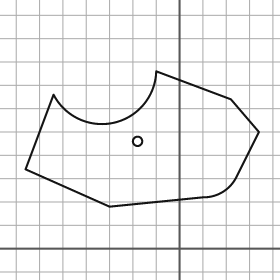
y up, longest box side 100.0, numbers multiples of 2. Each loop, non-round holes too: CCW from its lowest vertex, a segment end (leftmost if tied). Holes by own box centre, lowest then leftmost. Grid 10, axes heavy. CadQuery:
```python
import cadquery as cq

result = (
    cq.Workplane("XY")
    .moveTo(-30.0, 18.0)
    .lineTo(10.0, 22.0)
    .threePointArc((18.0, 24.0), (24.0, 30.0))
    .lineTo(34.0, 50.0)
    .lineTo(22.0, 64.0)
    .lineTo(-10.0, 76.0)
    .threePointArc((-28.0, 54.0), (-54.0, 66.0))
    .lineTo(-66.0, 34.0)
    .close()
    .moveTo(-18.0, 46.0)
    .circle(2.0)
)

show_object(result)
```